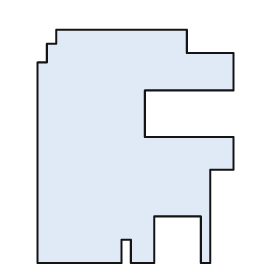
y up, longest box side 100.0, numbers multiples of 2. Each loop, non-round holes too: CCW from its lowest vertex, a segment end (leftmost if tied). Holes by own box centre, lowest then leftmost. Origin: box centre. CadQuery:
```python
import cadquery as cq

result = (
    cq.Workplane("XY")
    .moveTo(-42.0, -50.0)
    .lineTo(-6.0, -50.0)
    .lineTo(-6.0, -40.0)
    .lineTo(-2.0, -40.0)
    .lineTo(-2.0, -50.0)
    .lineTo(8.0, -50.0)
    .lineTo(8.0, -30.0)
    .lineTo(28.0, -30.0)
    .lineTo(28.0, -50.0)
    .lineTo(32.0, -50.0)
    .lineTo(32.0, -10.0)
    .lineTo(42.0, -10.0)
    .lineTo(42.0, 4.0)
    .lineTo(4.0, 4.0)
    .lineTo(4.0, 24.0)
    .lineTo(42.0, 24.0)
    .lineTo(42.0, 40.0)
    .lineTo(22.0, 40.0)
    .lineTo(22.0, 50.0)
    .lineTo(-34.0, 50.0)
    .lineTo(-34.0, 44.0)
    .lineTo(-38.0, 44.0)
    .lineTo(-38.0, 36.0)
    .lineTo(-42.0, 36.0)
    .close()
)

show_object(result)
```